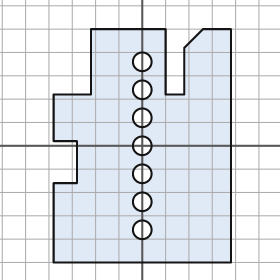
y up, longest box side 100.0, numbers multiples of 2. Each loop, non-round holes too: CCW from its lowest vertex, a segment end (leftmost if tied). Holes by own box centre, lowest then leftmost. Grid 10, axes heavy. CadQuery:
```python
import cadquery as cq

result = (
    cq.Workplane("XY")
    .moveTo(-38.0, -50.0)
    .lineTo(38.0, -50.0)
    .lineTo(38.0, 50.0)
    .lineTo(26.0, 50.0)
    .lineTo(18.0, 42.0)
    .lineTo(18.0, 22.0)
    .lineTo(10.0, 22.0)
    .lineTo(10.0, 50.0)
    .lineTo(-22.0, 50.0)
    .lineTo(-22.0, 22.0)
    .lineTo(-38.0, 22.0)
    .lineTo(-38.0, 2.0)
    .lineTo(-28.0, 2.0)
    .lineTo(-28.0, -16.0)
    .lineTo(-38.0, -16.0)
    .close()
    .moveTo(0.0, -36.0)
    .circle(4.0)
    .moveTo(0.0, -24.0)
    .circle(4.0)
    .moveTo(0.0, -12.0)
    .circle(4.0)
    .moveTo(0.0, 0.0)
    .circle(4.0)
    .moveTo(0.0, 12.0)
    .circle(4.0)
    .moveTo(0.0, 24.0)
    .circle(4.0)
    .moveTo(0.0, 36.0)
    .circle(4.0)
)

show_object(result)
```